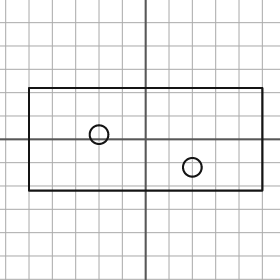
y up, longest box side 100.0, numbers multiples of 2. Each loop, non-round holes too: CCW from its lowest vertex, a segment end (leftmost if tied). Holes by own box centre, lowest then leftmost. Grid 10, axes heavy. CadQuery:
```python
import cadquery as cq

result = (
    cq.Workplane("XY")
    .moveTo(-50.0, -22.0)
    .lineTo(50.0, -22.0)
    .lineTo(50.0, 22.0)
    .lineTo(-50.0, 22.0)
    .close()
    .moveTo(20.0, -12.0)
    .circle(4.0)
    .moveTo(-20.0, 2.0)
    .circle(4.0)
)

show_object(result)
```